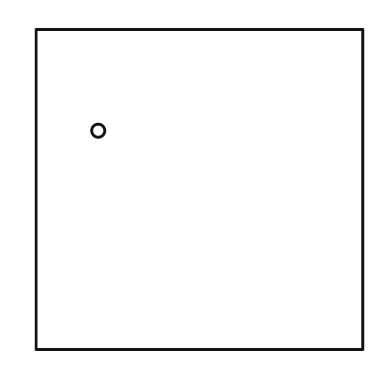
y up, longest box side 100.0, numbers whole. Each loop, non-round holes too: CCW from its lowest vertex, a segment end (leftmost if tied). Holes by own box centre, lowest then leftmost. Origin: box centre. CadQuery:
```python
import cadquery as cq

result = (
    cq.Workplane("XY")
    .moveTo(-50.0, -49.0)
    .lineTo(50.0, -49.0)
    .lineTo(50.0, 49.0)
    .lineTo(-50.0, 49.0)
    .close()
    .moveTo(-31.0, 18.0)
    .circle(2.0)
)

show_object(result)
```